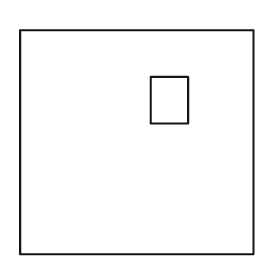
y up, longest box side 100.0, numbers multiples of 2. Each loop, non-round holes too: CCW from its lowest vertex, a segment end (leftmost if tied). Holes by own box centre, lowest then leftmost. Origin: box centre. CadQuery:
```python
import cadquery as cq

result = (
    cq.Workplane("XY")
    .moveTo(-50.0, -48.0)
    .lineTo(50.0, -48.0)
    .lineTo(50.0, 48.0)
    .lineTo(-50.0, 48.0)
    .close()
    .moveTo(6.0, 8.0)
    .lineTo(22.0, 8.0)
    .lineTo(22.0, 28.0)
    .lineTo(6.0, 28.0)
    .close()
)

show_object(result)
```